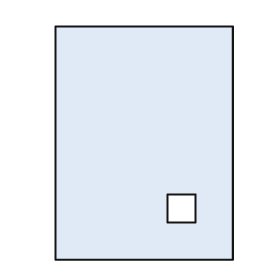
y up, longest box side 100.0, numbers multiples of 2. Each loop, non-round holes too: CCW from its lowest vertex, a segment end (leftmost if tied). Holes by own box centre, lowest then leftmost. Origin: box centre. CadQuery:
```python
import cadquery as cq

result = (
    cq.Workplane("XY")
    .moveTo(-38.0, -50.0)
    .lineTo(38.0, -50.0)
    .lineTo(38.0, 50.0)
    .lineTo(-38.0, 50.0)
    .close()
    .moveTo(10.0, -34.0)
    .lineTo(22.0, -34.0)
    .lineTo(22.0, -22.0)
    .lineTo(10.0, -22.0)
    .close()
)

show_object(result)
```